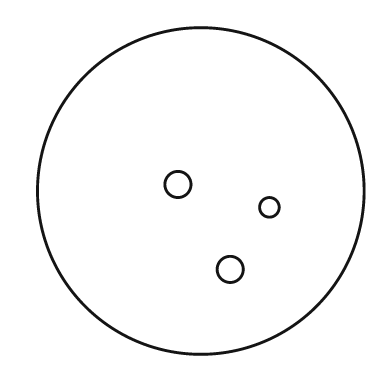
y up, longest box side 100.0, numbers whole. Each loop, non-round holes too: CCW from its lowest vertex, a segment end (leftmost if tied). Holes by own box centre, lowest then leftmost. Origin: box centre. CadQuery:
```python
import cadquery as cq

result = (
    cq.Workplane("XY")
    .moveTo(0.0, 0.0)
    .circle(50.0)
    .moveTo(9.0, -24.0)
    .circle(4.0)
    .moveTo(21.0, -5.0)
    .circle(3.0)
    .moveTo(-7.0, 2.0)
    .circle(4.0)
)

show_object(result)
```